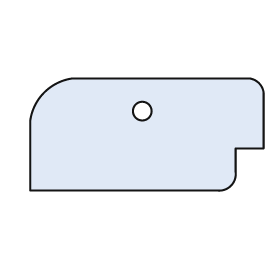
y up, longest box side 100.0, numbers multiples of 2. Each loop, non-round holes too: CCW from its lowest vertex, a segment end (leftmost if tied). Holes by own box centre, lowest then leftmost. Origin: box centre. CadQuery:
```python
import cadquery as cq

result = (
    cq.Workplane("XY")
    .moveTo(-50.0, -24.0)
    .lineTo(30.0, -24.0)
    .threePointArc((36.0, -22.0), (38.0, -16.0))
    .lineTo(38.0, -6.0)
    .lineTo(50.0, -6.0)
    .lineTo(50.0, 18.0)
    .threePointArc((48.0, 22.0), (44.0, 24.0))
    .lineTo(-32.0, 24.0)
    .threePointArc((-44.0, 18.0), (-50.0, 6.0))
    .close()
    .moveTo(-2.0, 10.0)
    .circle(4.0)
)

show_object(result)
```